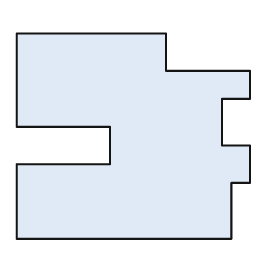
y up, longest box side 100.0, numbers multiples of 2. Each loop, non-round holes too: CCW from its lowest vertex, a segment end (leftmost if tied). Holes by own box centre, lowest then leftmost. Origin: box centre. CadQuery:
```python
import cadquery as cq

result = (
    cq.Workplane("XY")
    .moveTo(-50.0, -44.0)
    .lineTo(42.0, -44.0)
    .lineTo(42.0, -20.0)
    .lineTo(50.0, -20.0)
    .lineTo(50.0, -4.0)
    .lineTo(38.0, -4.0)
    .lineTo(38.0, 16.0)
    .lineTo(50.0, 16.0)
    .lineTo(50.0, 28.0)
    .lineTo(14.0, 28.0)
    .lineTo(14.0, 44.0)
    .lineTo(-50.0, 44.0)
    .lineTo(-50.0, 4.0)
    .lineTo(-10.0, 4.0)
    .lineTo(-10.0, -12.0)
    .lineTo(-50.0, -12.0)
    .close()
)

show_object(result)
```